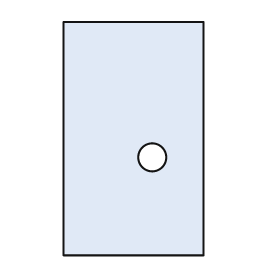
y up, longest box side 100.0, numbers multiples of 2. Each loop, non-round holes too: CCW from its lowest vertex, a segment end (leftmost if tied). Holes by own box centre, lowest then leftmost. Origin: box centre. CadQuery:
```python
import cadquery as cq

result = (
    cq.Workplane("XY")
    .moveTo(-30.0, -50.0)
    .lineTo(30.0, -50.0)
    .lineTo(30.0, 50.0)
    .lineTo(-30.0, 50.0)
    .close()
    .moveTo(8.0, -8.0)
    .circle(6.0)
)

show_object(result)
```